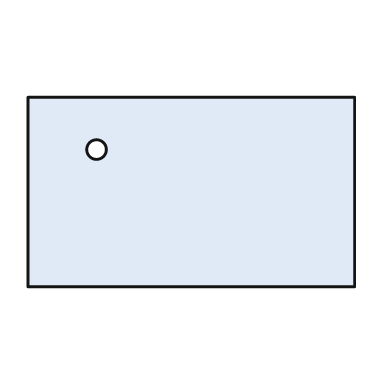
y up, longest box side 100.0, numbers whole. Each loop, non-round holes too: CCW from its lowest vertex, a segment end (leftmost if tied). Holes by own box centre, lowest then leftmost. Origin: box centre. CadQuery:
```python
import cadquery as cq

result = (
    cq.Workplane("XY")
    .moveTo(-50.0, -29.0)
    .lineTo(50.0, -29.0)
    .lineTo(50.0, 29.0)
    .lineTo(-50.0, 29.0)
    .close()
    .moveTo(-29.0, 13.0)
    .circle(3.0)
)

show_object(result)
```